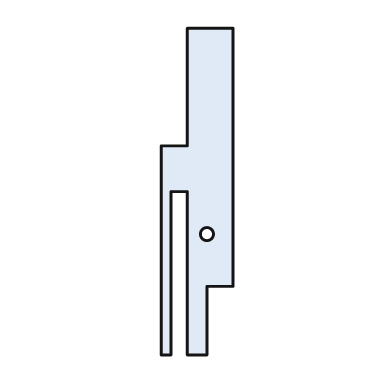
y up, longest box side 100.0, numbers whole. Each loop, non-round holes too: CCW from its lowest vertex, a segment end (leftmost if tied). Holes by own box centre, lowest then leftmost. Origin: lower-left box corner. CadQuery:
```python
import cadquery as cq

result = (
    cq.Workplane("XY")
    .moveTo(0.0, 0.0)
    .lineTo(3.0, 0.0)
    .lineTo(3.0, 50.0)
    .lineTo(8.0, 50.0)
    .lineTo(8.0, 0.0)
    .lineTo(14.0, 0.0)
    .lineTo(14.0, 21.0)
    .lineTo(22.0, 21.0)
    .lineTo(22.0, 100.0)
    .lineTo(8.0, 100.0)
    .lineTo(8.0, 64.0)
    .lineTo(0.0, 64.0)
    .close()
    .moveTo(14.0, 37.0)
    .circle(2.0)
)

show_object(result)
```